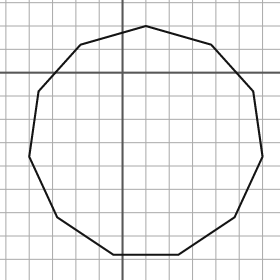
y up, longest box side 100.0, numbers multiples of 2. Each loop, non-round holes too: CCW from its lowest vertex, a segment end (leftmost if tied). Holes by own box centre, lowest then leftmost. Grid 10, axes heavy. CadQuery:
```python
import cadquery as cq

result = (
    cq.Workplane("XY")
    .moveTo(-4.0, -78.0)
    .lineTo(24.0, -78.0)
    .lineTo(48.0, -62.0)
    .lineTo(60.0, -36.0)
    .lineTo(56.0, -8.0)
    .lineTo(38.0, 12.0)
    .lineTo(10.0, 20.0)
    .lineTo(-18.0, 12.0)
    .lineTo(-36.0, -8.0)
    .lineTo(-40.0, -36.0)
    .lineTo(-28.0, -62.0)
    .close()
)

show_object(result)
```